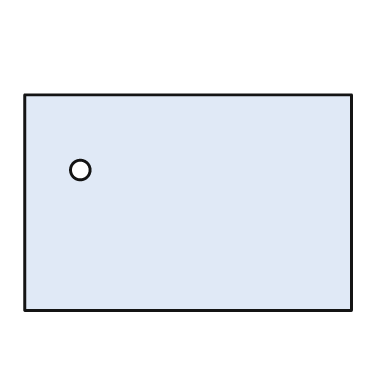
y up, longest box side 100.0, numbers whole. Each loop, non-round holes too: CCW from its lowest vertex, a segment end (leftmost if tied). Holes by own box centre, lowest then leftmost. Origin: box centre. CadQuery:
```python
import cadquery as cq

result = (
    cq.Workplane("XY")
    .moveTo(-50.0, -33.0)
    .lineTo(50.0, -33.0)
    .lineTo(50.0, 33.0)
    .lineTo(-50.0, 33.0)
    .close()
    .moveTo(-33.0, 10.0)
    .circle(3.0)
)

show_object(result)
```